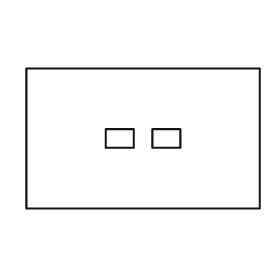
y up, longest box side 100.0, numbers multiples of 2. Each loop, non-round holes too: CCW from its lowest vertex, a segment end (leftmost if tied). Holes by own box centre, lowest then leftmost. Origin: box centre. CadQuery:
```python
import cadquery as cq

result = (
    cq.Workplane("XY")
    .moveTo(-50.0, -30.0)
    .lineTo(50.0, -30.0)
    .lineTo(50.0, 30.0)
    .lineTo(-50.0, 30.0)
    .close()
    .moveTo(-16.0, -4.0)
    .lineTo(-4.0, -4.0)
    .lineTo(-4.0, 4.0)
    .lineTo(-16.0, 4.0)
    .close()
    .moveTo(4.0, -4.0)
    .lineTo(16.0, -4.0)
    .lineTo(16.0, 4.0)
    .lineTo(4.0, 4.0)
    .close()
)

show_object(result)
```